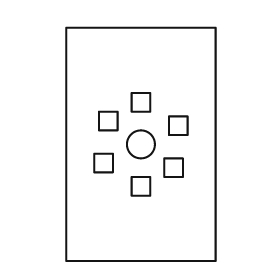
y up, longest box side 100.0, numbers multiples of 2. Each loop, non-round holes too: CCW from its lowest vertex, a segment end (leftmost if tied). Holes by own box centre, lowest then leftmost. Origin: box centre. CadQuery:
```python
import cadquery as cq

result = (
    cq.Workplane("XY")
    .moveTo(-32.0, -50.0)
    .lineTo(32.0, -50.0)
    .lineTo(32.0, 50.0)
    .lineTo(-32.0, 50.0)
    .close()
    .moveTo(-4.0, -22.0)
    .lineTo(4.0, -22.0)
    .lineTo(4.0, -14.0)
    .lineTo(-4.0, -14.0)
    .close()
    .moveTo(10.0, -14.0)
    .lineTo(18.0, -14.0)
    .lineTo(18.0, -6.0)
    .lineTo(10.0, -6.0)
    .close()
    .moveTo(-20.0, -12.0)
    .lineTo(-12.0, -12.0)
    .lineTo(-12.0, -4.0)
    .lineTo(-20.0, -4.0)
    .close()
    .moveTo(0.0, 0.0)
    .circle(6.0)
    .moveTo(12.0, 4.0)
    .lineTo(20.0, 4.0)
    .lineTo(20.0, 12.0)
    .lineTo(12.0, 12.0)
    .close()
    .moveTo(-18.0, 6.0)
    .lineTo(-10.0, 6.0)
    .lineTo(-10.0, 14.0)
    .lineTo(-18.0, 14.0)
    .close()
    .moveTo(-4.0, 14.0)
    .lineTo(4.0, 14.0)
    .lineTo(4.0, 22.0)
    .lineTo(-4.0, 22.0)
    .close()
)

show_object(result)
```